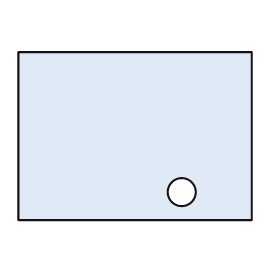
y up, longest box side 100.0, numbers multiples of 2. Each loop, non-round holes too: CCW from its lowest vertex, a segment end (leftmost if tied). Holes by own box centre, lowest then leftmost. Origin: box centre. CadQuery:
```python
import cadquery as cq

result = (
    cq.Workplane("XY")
    .moveTo(-50.0, -36.0)
    .lineTo(50.0, -36.0)
    .lineTo(50.0, 36.0)
    .lineTo(-50.0, 36.0)
    .close()
    .moveTo(20.0, -24.0)
    .circle(6.0)
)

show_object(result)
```